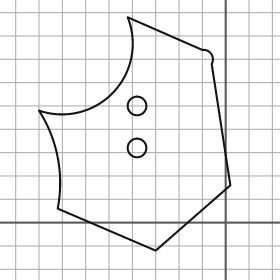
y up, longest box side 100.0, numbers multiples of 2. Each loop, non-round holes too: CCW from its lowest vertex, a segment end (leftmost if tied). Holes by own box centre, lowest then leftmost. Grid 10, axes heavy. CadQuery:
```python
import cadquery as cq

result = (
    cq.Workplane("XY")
    .moveTo(-30.0, -12.0)
    .lineTo(2.0, 16.0)
    .lineTo(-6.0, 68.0)
    .threePointArc((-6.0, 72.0), (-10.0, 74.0))
    .lineTo(-42.0, 88.0)
    .threePointArc((-48.0, 56.0), (-80.0, 48.0))
    .threePointArc((-72.0, 28.0), (-72.0, 6.0))
    .close()
    .moveTo(-38.0, 32.0)
    .circle(4.0)
    .moveTo(-38.0, 50.0)
    .circle(4.0)
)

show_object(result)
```